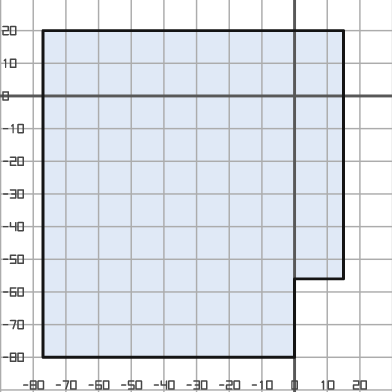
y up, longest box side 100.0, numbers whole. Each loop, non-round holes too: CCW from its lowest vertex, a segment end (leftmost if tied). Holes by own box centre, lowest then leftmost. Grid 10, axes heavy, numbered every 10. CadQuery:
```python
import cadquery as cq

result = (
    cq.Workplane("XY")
    .moveTo(-77.0, -80.0)
    .lineTo(0.0, -80.0)
    .lineTo(0.0, -56.0)
    .lineTo(15.0, -56.0)
    .lineTo(15.0, 20.0)
    .lineTo(-77.0, 20.0)
    .close()
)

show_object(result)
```